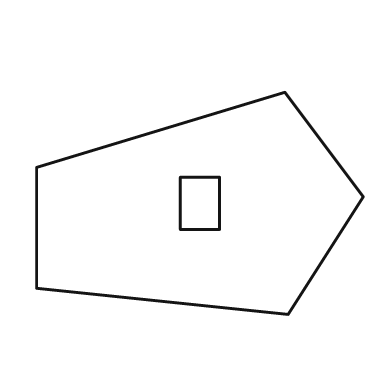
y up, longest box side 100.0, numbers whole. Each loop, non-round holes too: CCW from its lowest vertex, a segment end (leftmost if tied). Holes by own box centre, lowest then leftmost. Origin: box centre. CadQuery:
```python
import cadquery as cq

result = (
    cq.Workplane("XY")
    .moveTo(27.0, -34.0)
    .lineTo(50.0, 2.0)
    .lineTo(26.0, 34.0)
    .lineTo(-50.0, 11.0)
    .lineTo(-50.0, -26.0)
    .close()
    .moveTo(-6.0, -8.0)
    .lineTo(6.0, -8.0)
    .lineTo(6.0, 8.0)
    .lineTo(-6.0, 8.0)
    .close()
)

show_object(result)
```